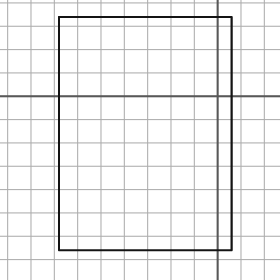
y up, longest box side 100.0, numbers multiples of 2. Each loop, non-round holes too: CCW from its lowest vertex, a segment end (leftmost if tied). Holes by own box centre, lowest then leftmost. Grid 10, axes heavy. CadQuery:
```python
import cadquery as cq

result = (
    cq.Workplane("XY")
    .moveTo(-68.0, -66.0)
    .lineTo(6.0, -66.0)
    .lineTo(6.0, 34.0)
    .lineTo(-68.0, 34.0)
    .close()
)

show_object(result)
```